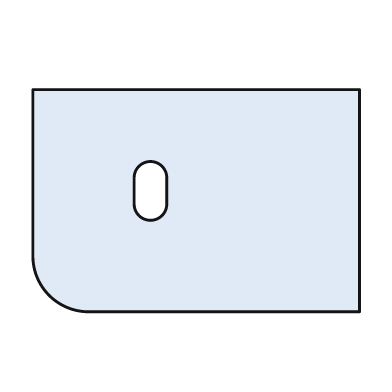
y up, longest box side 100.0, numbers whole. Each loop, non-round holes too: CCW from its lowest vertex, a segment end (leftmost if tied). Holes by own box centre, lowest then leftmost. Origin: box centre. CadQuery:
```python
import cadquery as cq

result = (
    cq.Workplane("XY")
    .moveTo(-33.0, -34.0)
    .lineTo(50.0, -34.0)
    .lineTo(50.0, 34.0)
    .lineTo(-50.0, 34.0)
    .lineTo(-50.0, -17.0)
    .threePointArc((-45.0, -29.0), (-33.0, -34.0))
    .close()
    .moveTo(-19.0, -1.0)
    .threePointArc((-14.0, -6.0), (-9.0, -1.0))
    .lineTo(-9.0, 7.0)
    .threePointArc((-14.0, 12.0), (-19.0, 7.0))
    .close()
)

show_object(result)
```